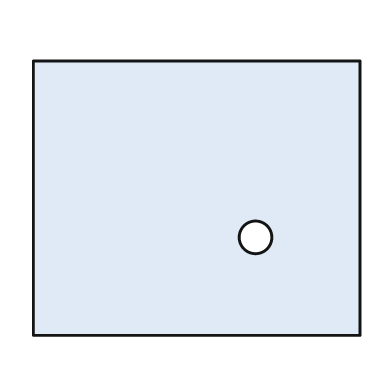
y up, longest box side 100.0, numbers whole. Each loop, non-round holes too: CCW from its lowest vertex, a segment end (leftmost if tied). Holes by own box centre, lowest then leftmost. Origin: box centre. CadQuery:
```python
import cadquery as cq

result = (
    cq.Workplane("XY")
    .moveTo(-50.0, -42.0)
    .lineTo(50.0, -42.0)
    .lineTo(50.0, 42.0)
    .lineTo(-50.0, 42.0)
    .close()
    .moveTo(18.0, -12.0)
    .circle(5.0)
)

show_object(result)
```